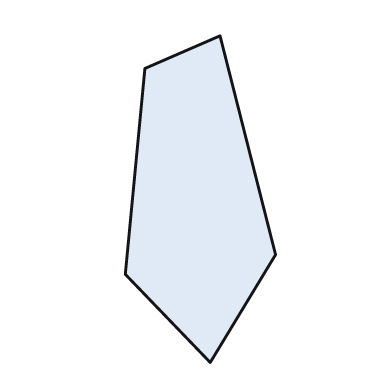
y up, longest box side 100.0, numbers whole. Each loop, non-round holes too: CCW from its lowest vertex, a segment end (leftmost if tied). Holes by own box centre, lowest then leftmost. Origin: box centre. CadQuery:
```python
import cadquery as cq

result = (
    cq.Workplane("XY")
    .moveTo(3.0, -50.0)
    .lineTo(23.0, -17.0)
    .lineTo(6.0, 50.0)
    .lineTo(-17.0, 40.0)
    .lineTo(-23.0, -23.0)
    .close()
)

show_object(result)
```